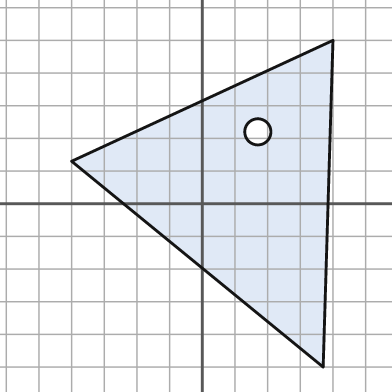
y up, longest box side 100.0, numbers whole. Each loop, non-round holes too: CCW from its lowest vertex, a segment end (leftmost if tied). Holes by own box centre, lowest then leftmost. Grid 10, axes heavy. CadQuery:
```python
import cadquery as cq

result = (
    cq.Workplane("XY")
    .moveTo(37.0, -50.0)
    .lineTo(40.0, 50.0)
    .lineTo(-40.0, 13.0)
    .close()
    .moveTo(17.0, 22.0)
    .circle(4.0)
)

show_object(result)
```